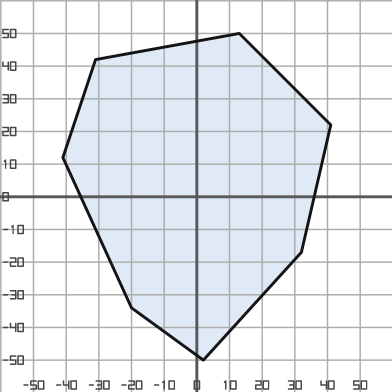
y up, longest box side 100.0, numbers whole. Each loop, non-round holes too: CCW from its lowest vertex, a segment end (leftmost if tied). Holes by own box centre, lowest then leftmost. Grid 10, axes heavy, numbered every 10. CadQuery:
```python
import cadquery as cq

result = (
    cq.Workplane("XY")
    .moveTo(2.0, -50.0)
    .lineTo(32.0, -17.0)
    .lineTo(41.0, 22.0)
    .lineTo(13.0, 50.0)
    .lineTo(-31.0, 42.0)
    .lineTo(-41.0, 12.0)
    .lineTo(-20.0, -34.0)
    .close()
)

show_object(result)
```